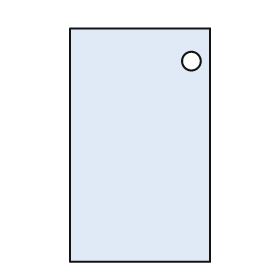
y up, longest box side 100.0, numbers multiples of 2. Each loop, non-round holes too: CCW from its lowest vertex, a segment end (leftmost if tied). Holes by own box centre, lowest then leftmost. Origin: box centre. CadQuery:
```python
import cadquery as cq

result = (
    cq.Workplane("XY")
    .moveTo(-30.0, -50.0)
    .lineTo(30.0, -50.0)
    .lineTo(30.0, 50.0)
    .lineTo(-30.0, 50.0)
    .close()
    .moveTo(22.0, 36.0)
    .circle(4.0)
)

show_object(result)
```